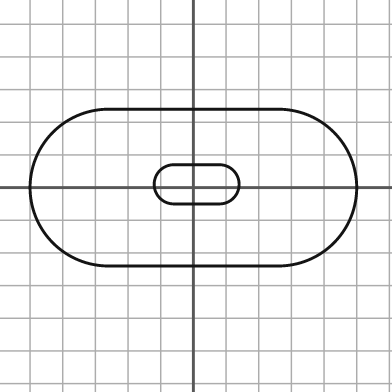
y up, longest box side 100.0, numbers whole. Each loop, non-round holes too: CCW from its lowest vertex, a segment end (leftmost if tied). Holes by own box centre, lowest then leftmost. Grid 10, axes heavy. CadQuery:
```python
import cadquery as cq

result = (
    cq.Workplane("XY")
    .moveTo(-26.0, -24.0)
    .lineTo(26.0, -24.0)
    .threePointArc((50.0, 0.0), (26.0, 24.0))
    .lineTo(-26.0, 24.0)
    .threePointArc((-50.0, 0.0), (-26.0, -24.0))
    .close()
    .moveTo(-6.0, -5.0)
    .lineTo(8.0, -5.0)
    .threePointArc((14.0, 1.0), (8.0, 7.0))
    .lineTo(-6.0, 7.0)
    .threePointArc((-12.0, 1.0), (-6.0, -5.0))
    .close()
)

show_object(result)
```